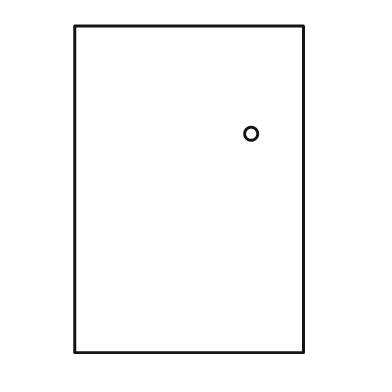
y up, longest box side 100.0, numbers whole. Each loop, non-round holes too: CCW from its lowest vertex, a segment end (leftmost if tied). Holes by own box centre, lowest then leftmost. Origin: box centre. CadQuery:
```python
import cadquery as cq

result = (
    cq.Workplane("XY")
    .moveTo(-35.0, -50.0)
    .lineTo(35.0, -50.0)
    .lineTo(35.0, 50.0)
    .lineTo(-35.0, 50.0)
    .close()
    .moveTo(19.0, 17.0)
    .circle(2.0)
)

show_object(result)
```